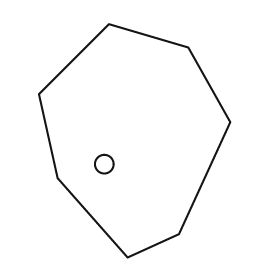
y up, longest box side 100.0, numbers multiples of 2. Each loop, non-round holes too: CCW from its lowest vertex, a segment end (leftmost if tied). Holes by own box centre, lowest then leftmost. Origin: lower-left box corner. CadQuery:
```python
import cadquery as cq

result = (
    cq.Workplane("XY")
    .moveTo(38.0, 0.0)
    .lineTo(60.0, 10.0)
    .lineTo(82.0, 58.0)
    .lineTo(64.0, 90.0)
    .lineTo(30.0, 100.0)
    .lineTo(0.0, 70.0)
    .lineTo(8.0, 34.0)
    .close()
    .moveTo(28.0, 40.0)
    .circle(4.0)
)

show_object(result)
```